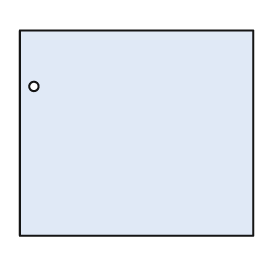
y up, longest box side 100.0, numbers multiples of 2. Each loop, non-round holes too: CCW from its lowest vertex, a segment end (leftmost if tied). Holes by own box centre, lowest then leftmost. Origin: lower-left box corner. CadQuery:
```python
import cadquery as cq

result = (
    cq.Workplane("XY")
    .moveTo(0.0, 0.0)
    .lineTo(100.0, 0.0)
    .lineTo(100.0, 88.0)
    .lineTo(0.0, 88.0)
    .close()
    .moveTo(6.0, 64.0)
    .circle(2.0)
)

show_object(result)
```